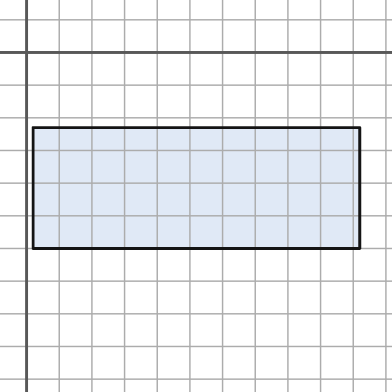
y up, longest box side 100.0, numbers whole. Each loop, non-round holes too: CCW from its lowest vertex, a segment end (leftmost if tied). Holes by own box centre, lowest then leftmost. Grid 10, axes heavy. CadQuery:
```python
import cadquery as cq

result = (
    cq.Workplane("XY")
    .moveTo(2.0, -60.0)
    .lineTo(102.0, -60.0)
    .lineTo(102.0, -23.0)
    .lineTo(2.0, -23.0)
    .close()
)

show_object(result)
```